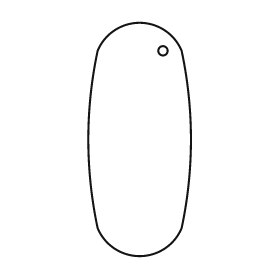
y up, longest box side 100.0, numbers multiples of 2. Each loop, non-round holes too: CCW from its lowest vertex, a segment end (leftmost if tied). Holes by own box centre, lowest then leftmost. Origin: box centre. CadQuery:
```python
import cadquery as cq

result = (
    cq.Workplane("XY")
    .moveTo(-18.0, -38.0)
    .threePointArc((0.0, -50.0), (18.0, -38.0))
    .threePointArc((22.0, 0.0), (18.0, 38.0))
    .threePointArc((0.0, 50.0), (-18.0, 38.0))
    .threePointArc((-22.0, 0.0), (-18.0, -38.0))
    .close()
    .moveTo(10.0, 38.0)
    .circle(2.0)
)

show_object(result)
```